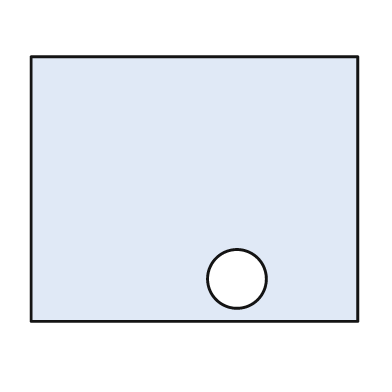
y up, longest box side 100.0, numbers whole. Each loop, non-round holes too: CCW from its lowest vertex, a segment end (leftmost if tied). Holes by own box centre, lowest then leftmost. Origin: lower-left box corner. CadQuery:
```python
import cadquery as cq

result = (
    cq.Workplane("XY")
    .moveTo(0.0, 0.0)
    .lineTo(100.0, 0.0)
    .lineTo(100.0, 81.0)
    .lineTo(0.0, 81.0)
    .close()
    .moveTo(63.0, 13.0)
    .circle(9.0)
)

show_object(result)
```